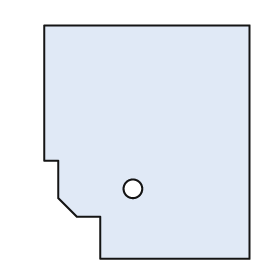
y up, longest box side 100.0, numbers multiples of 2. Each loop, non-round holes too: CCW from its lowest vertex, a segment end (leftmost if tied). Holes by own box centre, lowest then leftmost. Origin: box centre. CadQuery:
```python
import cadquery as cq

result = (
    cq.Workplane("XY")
    .moveTo(-20.0, -50.0)
    .lineTo(44.0, -50.0)
    .lineTo(44.0, 50.0)
    .lineTo(-44.0, 50.0)
    .lineTo(-44.0, -8.0)
    .lineTo(-38.0, -8.0)
    .lineTo(-38.0, -24.0)
    .lineTo(-30.0, -32.0)
    .lineTo(-20.0, -32.0)
    .close()
    .moveTo(-6.0, -20.0)
    .circle(4.0)
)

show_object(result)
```